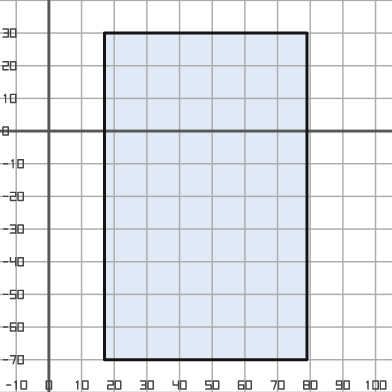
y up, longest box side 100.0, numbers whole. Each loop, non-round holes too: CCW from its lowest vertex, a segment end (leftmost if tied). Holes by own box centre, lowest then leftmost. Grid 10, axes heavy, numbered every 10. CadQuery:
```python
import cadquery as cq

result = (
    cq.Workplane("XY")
    .moveTo(17.0, -70.0)
    .lineTo(79.0, -70.0)
    .lineTo(79.0, 30.0)
    .lineTo(17.0, 30.0)
    .close()
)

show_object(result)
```